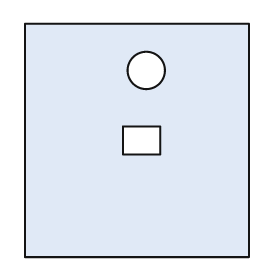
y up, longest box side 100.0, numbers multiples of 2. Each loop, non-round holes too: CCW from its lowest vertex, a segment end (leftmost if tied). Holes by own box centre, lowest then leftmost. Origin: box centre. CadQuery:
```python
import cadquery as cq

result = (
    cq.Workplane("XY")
    .moveTo(-48.0, -50.0)
    .lineTo(48.0, -50.0)
    .lineTo(48.0, 50.0)
    .lineTo(-48.0, 50.0)
    .close()
    .moveTo(-6.0, -6.0)
    .lineTo(10.0, -6.0)
    .lineTo(10.0, 6.0)
    .lineTo(-6.0, 6.0)
    .close()
    .moveTo(4.0, 30.0)
    .circle(8.0)
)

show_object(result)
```